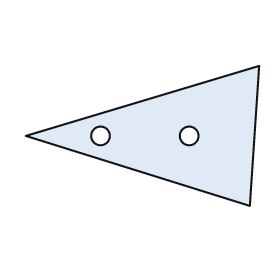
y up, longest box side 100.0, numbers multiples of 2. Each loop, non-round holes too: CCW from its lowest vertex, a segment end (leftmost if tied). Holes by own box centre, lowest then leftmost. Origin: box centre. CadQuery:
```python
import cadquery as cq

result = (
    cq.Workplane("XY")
    .moveTo(46.0, -30.0)
    .lineTo(50.0, 30.0)
    .lineTo(-50.0, 0.0)
    .close()
    .moveTo(-18.0, 0.0)
    .circle(4.0)
    .moveTo(20.0, 0.0)
    .circle(4.0)
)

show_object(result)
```